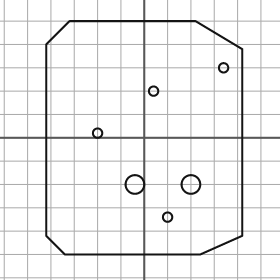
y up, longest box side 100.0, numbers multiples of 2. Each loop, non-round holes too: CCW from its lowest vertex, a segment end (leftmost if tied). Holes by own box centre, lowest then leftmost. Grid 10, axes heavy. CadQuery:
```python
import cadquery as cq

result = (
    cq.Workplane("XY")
    .moveTo(-34.0, -50.0)
    .lineTo(24.0, -50.0)
    .lineTo(42.0, -42.0)
    .lineTo(42.0, 38.0)
    .lineTo(22.0, 50.0)
    .lineTo(-32.0, 50.0)
    .lineTo(-42.0, 40.0)
    .lineTo(-42.0, -42.0)
    .close()
    .moveTo(10.0, -34.0)
    .circle(2.0)
    .moveTo(-4.0, -20.0)
    .circle(4.0)
    .moveTo(20.0, -20.0)
    .circle(4.0)
    .moveTo(-20.0, 2.0)
    .circle(2.0)
    .moveTo(4.0, 20.0)
    .circle(2.0)
    .moveTo(34.0, 30.0)
    .circle(2.0)
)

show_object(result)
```